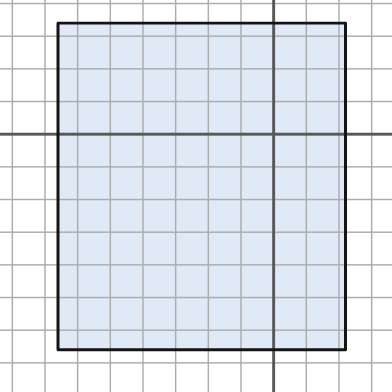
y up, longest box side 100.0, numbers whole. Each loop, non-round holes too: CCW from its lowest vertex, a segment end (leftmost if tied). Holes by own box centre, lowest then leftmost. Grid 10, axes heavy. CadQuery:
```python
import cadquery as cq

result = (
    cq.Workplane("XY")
    .moveTo(-66.0, -66.0)
    .lineTo(22.0, -66.0)
    .lineTo(22.0, 34.0)
    .lineTo(-66.0, 34.0)
    .close()
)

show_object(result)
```